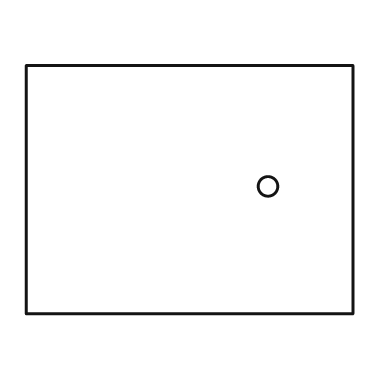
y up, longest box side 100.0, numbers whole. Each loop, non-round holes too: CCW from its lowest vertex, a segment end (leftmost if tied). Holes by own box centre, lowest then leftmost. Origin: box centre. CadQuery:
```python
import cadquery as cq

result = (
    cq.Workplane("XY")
    .moveTo(-50.0, -38.0)
    .lineTo(50.0, -38.0)
    .lineTo(50.0, 38.0)
    .lineTo(-50.0, 38.0)
    .close()
    .moveTo(24.0, 1.0)
    .circle(3.0)
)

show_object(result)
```